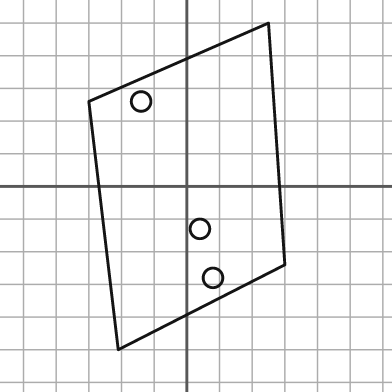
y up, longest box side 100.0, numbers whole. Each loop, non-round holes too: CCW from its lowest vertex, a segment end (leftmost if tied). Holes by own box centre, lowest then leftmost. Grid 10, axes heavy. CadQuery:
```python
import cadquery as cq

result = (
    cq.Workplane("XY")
    .moveTo(-21.0, -50.0)
    .lineTo(30.0, -24.0)
    .lineTo(25.0, 50.0)
    .lineTo(-30.0, 26.0)
    .close()
    .moveTo(8.0, -28.0)
    .circle(3.0)
    .moveTo(4.0, -13.0)
    .circle(3.0)
    .moveTo(-14.0, 26.0)
    .circle(3.0)
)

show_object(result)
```